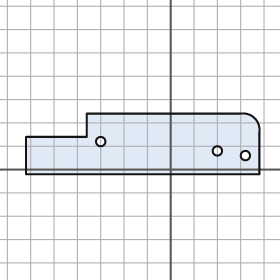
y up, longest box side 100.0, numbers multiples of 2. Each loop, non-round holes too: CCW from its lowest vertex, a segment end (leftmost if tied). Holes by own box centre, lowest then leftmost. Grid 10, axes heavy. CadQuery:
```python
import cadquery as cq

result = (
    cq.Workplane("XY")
    .moveTo(-62.0, -2.0)
    .lineTo(38.0, -2.0)
    .lineTo(38.0, 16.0)
    .threePointArc((36.0, 22.0), (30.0, 24.0))
    .lineTo(-36.0, 24.0)
    .lineTo(-36.0, 14.0)
    .lineTo(-62.0, 14.0)
    .close()
    .moveTo(32.0, 6.0)
    .circle(2.0)
    .moveTo(20.0, 8.0)
    .circle(2.0)
    .moveTo(-30.0, 12.0)
    .circle(2.0)
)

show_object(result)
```